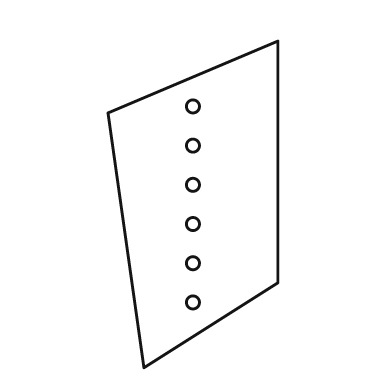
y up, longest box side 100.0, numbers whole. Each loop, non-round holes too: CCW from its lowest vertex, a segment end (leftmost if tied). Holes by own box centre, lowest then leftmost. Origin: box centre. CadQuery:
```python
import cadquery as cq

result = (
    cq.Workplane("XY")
    .moveTo(-15.0, -50.0)
    .lineTo(26.0, -24.0)
    .lineTo(26.0, 50.0)
    .lineTo(-26.0, 28.0)
    .close()
    .moveTo(0.0, -30.0)
    .circle(2.0)
    .moveTo(0.0, -18.0)
    .circle(2.0)
    .moveTo(0.0, -6.0)
    .circle(2.0)
    .moveTo(0.0, 6.0)
    .circle(2.0)
    .moveTo(0.0, 18.0)
    .circle(2.0)
    .moveTo(0.0, 30.0)
    .circle(2.0)
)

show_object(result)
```